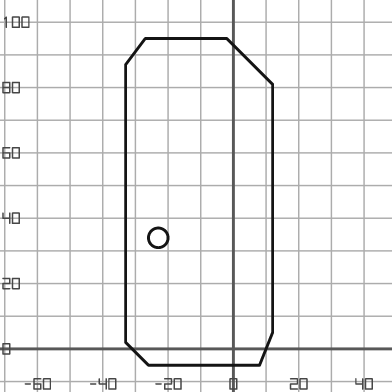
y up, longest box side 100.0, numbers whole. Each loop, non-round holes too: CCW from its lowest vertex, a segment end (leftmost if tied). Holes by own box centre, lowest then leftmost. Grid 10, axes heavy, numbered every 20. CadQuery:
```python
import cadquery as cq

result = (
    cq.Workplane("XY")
    .moveTo(-26.0, -5.0)
    .lineTo(8.0, -5.0)
    .lineTo(12.0, 5.0)
    .lineTo(12.0, 81.0)
    .lineTo(-2.0, 95.0)
    .lineTo(-27.0, 95.0)
    .lineTo(-33.0, 87.0)
    .lineTo(-33.0, 2.0)
    .close()
    .moveTo(-23.0, 34.0)
    .circle(3.0)
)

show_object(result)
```